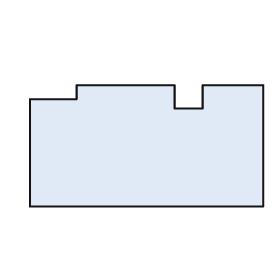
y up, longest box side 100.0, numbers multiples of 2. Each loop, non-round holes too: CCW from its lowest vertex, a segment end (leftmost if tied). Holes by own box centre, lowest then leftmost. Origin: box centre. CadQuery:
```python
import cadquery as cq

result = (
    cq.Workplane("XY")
    .moveTo(-50.0, -26.0)
    .lineTo(50.0, -26.0)
    .lineTo(50.0, 26.0)
    .lineTo(24.0, 26.0)
    .lineTo(24.0, 16.0)
    .lineTo(12.0, 16.0)
    .lineTo(12.0, 26.0)
    .lineTo(-30.0, 26.0)
    .lineTo(-30.0, 20.0)
    .lineTo(-50.0, 20.0)
    .close()
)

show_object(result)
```